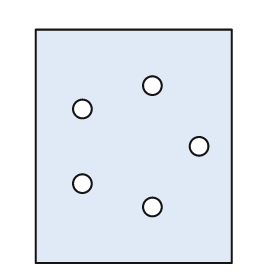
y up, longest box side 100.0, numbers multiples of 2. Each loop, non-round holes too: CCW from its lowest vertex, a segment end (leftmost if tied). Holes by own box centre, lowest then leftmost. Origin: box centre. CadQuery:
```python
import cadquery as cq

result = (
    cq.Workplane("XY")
    .moveTo(-42.0, -50.0)
    .lineTo(42.0, -50.0)
    .lineTo(42.0, 50.0)
    .lineTo(-42.0, 50.0)
    .close()
    .moveTo(8.0, -26.0)
    .circle(4.0)
    .moveTo(-22.0, -16.0)
    .circle(4.0)
    .moveTo(28.0, 0.0)
    .circle(4.0)
    .moveTo(-22.0, 16.0)
    .circle(4.0)
    .moveTo(8.0, 26.0)
    .circle(4.0)
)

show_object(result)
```